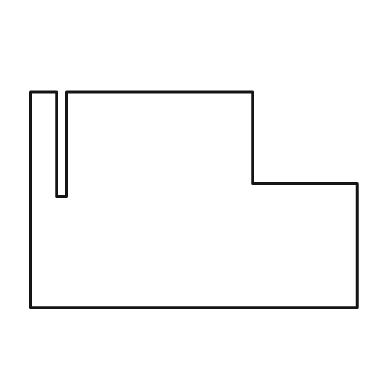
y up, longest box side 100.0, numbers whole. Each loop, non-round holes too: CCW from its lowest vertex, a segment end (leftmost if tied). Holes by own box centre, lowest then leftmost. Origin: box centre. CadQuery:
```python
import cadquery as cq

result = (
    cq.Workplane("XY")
    .moveTo(-50.0, -33.0)
    .lineTo(50.0, -33.0)
    .lineTo(50.0, 5.0)
    .lineTo(18.0, 5.0)
    .lineTo(18.0, 33.0)
    .lineTo(-39.0, 33.0)
    .lineTo(-39.0, 1.0)
    .lineTo(-42.0, 1.0)
    .lineTo(-42.0, 33.0)
    .lineTo(-50.0, 33.0)
    .close()
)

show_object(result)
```